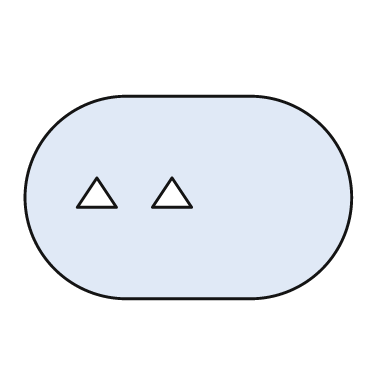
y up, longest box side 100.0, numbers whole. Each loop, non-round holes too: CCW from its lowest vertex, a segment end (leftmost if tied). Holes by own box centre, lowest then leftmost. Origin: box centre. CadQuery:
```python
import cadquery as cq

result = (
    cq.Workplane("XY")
    .moveTo(-19.0, -31.0)
    .lineTo(19.0, -31.0)
    .threePointArc((50.0, 0.0), (19.0, 31.0))
    .lineTo(-19.0, 31.0)
    .threePointArc((-50.0, 0.0), (-19.0, -31.0))
    .close()
    .moveTo(-34.0, -3.0)
    .lineTo(-22.0, -3.0)
    .lineTo(-28.0, 6.0)
    .close()
    .moveTo(-11.0, -3.0)
    .lineTo(1.0, -3.0)
    .lineTo(-5.0, 6.0)
    .close()
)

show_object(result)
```